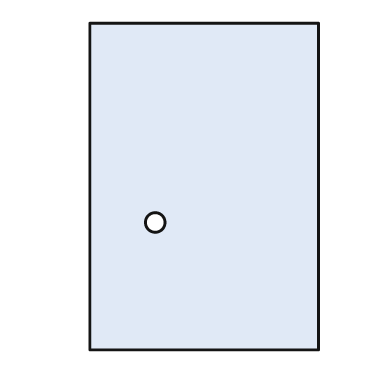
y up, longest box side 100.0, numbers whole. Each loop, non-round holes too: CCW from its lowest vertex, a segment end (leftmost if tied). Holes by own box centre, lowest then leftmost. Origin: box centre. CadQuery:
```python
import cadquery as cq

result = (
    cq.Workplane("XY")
    .moveTo(-35.0, -50.0)
    .lineTo(35.0, -50.0)
    .lineTo(35.0, 50.0)
    .lineTo(-35.0, 50.0)
    .close()
    .moveTo(-15.0, -11.0)
    .circle(3.0)
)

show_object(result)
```